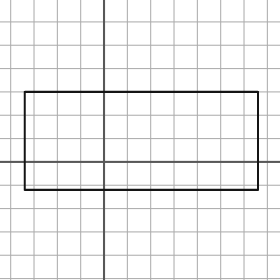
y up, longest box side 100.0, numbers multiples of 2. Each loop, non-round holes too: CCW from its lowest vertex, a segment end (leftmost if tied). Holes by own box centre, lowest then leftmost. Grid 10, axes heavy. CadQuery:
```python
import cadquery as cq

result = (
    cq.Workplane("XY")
    .moveTo(-34.0, -12.0)
    .lineTo(66.0, -12.0)
    .lineTo(66.0, 30.0)
    .lineTo(-34.0, 30.0)
    .close()
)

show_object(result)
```